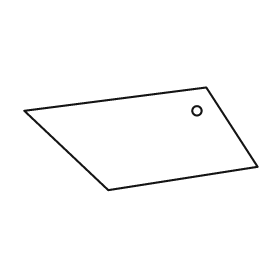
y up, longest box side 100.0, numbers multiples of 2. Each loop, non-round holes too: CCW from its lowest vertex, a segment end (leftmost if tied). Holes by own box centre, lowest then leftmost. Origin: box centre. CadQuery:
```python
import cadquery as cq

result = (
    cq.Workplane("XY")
    .moveTo(-14.0, -22.0)
    .lineTo(50.0, -12.0)
    .lineTo(28.0, 22.0)
    .lineTo(-50.0, 12.0)
    .close()
    .moveTo(24.0, 12.0)
    .circle(2.0)
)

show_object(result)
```